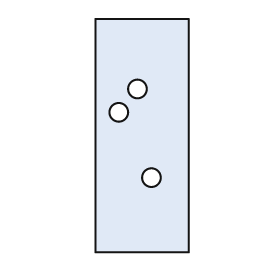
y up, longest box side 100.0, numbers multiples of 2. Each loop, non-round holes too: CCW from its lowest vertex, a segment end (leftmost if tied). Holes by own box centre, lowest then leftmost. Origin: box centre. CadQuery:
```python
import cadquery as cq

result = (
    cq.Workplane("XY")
    .moveTo(-20.0, -50.0)
    .lineTo(20.0, -50.0)
    .lineTo(20.0, 50.0)
    .lineTo(-20.0, 50.0)
    .close()
    .moveTo(4.0, -18.0)
    .circle(4.0)
    .moveTo(-10.0, 10.0)
    .circle(4.0)
    .moveTo(-2.0, 20.0)
    .circle(4.0)
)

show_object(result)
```